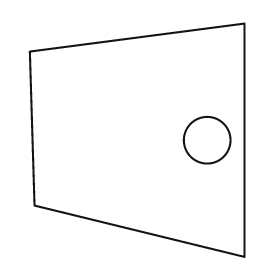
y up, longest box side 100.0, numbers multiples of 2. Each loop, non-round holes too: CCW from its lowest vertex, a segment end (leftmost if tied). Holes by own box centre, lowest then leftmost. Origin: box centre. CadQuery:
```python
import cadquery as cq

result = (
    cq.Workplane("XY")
    .moveTo(46.0, -50.0)
    .lineTo(46.0, 50.0)
    .lineTo(-46.0, 38.0)
    .lineTo(-44.0, -28.0)
    .close()
    .moveTo(30.0, 0.0)
    .circle(10.0)
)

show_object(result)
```